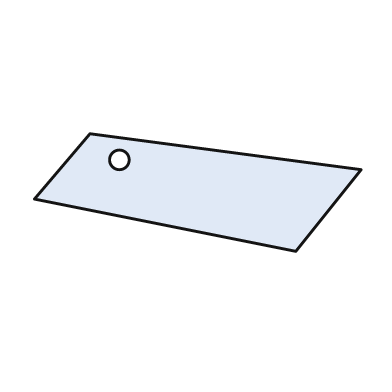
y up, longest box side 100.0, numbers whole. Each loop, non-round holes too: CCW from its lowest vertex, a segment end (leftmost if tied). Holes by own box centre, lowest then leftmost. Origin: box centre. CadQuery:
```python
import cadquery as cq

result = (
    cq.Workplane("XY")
    .moveTo(30.0, -18.0)
    .lineTo(50.0, 7.0)
    .lineTo(-33.0, 18.0)
    .lineTo(-50.0, -2.0)
    .close()
    .moveTo(-24.0, 10.0)
    .circle(3.0)
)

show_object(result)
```